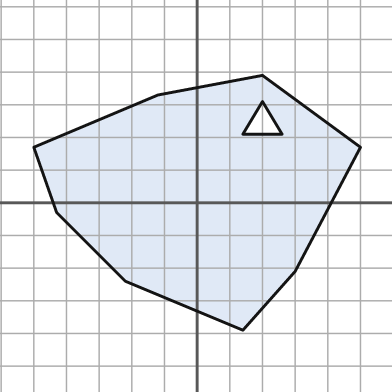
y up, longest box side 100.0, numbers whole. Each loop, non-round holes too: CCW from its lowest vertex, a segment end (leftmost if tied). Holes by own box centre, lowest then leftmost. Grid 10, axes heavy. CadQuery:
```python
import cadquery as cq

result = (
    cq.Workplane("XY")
    .moveTo(14.0, -39.0)
    .lineTo(30.0, -21.0)
    .lineTo(50.0, 17.0)
    .lineTo(20.0, 39.0)
    .lineTo(-12.0, 33.0)
    .lineTo(-50.0, 17.0)
    .lineTo(-43.0, -3.0)
    .lineTo(-22.0, -24.0)
    .close()
    .moveTo(14.0, 21.0)
    .lineTo(26.0, 21.0)
    .lineTo(20.0, 31.0)
    .close()
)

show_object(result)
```